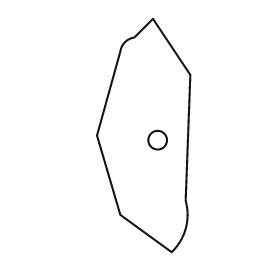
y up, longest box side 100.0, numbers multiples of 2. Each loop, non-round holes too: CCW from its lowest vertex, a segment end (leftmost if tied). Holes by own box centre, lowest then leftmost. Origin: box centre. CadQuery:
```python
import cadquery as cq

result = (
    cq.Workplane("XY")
    .moveTo(12.0, -50.0)
    .threePointArc((18.0, -40.0), (18.0, -28.0))
    .lineTo(20.0, 26.0)
    .lineTo(4.0, 50.0)
    .lineTo(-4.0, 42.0)
    .threePointArc((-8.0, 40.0), (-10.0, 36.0))
    .lineTo(-20.0, 0.0)
    .lineTo(-10.0, -34.0)
    .close()
    .moveTo(6.0, -2.0)
    .circle(4.0)
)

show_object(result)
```